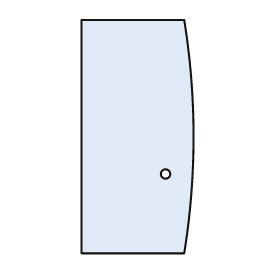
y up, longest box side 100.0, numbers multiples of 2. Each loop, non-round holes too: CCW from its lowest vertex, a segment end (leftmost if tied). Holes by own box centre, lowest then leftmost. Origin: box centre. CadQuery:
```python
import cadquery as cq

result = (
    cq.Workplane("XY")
    .moveTo(-24.0, -50.0)
    .lineTo(20.0, -50.0)
    .threePointArc((24.0, 0.0), (20.0, 50.0))
    .lineTo(-24.0, 50.0)
    .close()
    .moveTo(12.0, -16.0)
    .circle(2.0)
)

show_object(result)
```